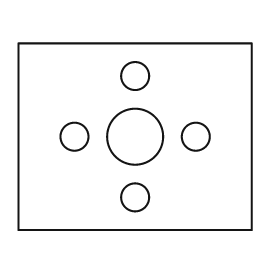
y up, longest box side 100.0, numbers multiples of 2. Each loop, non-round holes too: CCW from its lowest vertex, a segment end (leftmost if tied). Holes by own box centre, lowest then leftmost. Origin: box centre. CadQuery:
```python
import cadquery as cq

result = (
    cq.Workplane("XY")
    .moveTo(-50.0, -40.0)
    .lineTo(50.0, -40.0)
    .lineTo(50.0, 40.0)
    .lineTo(-50.0, 40.0)
    .close()
    .moveTo(0.0, -26.0)
    .circle(6.0)
    .moveTo(-26.0, 0.0)
    .circle(6.0)
    .moveTo(0.0, 0.0)
    .circle(12.0)
    .moveTo(26.0, 0.0)
    .circle(6.0)
    .moveTo(0.0, 26.0)
    .circle(6.0)
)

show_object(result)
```